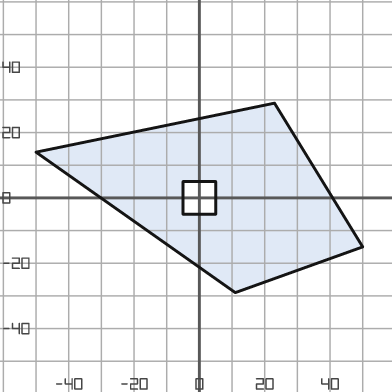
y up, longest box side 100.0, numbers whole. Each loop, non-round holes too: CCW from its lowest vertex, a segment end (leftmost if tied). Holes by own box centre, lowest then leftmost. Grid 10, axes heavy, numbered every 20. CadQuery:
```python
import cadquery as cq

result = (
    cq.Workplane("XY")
    .moveTo(11.0, -29.0)
    .lineTo(50.0, -15.0)
    .lineTo(23.0, 29.0)
    .lineTo(-50.0, 14.0)
    .close()
    .moveTo(-5.0, -5.0)
    .lineTo(5.0, -5.0)
    .lineTo(5.0, 5.0)
    .lineTo(-5.0, 5.0)
    .close()
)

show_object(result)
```